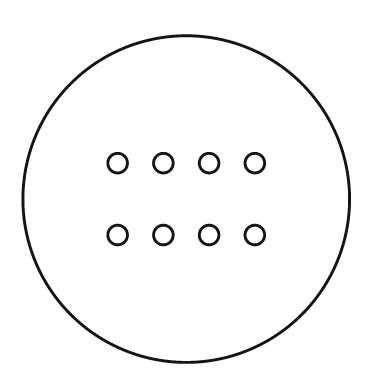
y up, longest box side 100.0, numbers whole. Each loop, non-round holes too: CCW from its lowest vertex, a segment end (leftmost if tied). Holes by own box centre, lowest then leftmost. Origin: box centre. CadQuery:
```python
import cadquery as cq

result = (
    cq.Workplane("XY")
    .moveTo(0.0, 0.0)
    .circle(50.0)
    .moveTo(-21.0, -11.0)
    .circle(3.0)
    .moveTo(-7.0, -11.0)
    .circle(3.0)
    .moveTo(7.0, -11.0)
    .circle(3.0)
    .moveTo(21.0, -11.0)
    .circle(3.0)
    .moveTo(-21.0, 11.0)
    .circle(3.0)
    .moveTo(-7.0, 11.0)
    .circle(3.0)
    .moveTo(7.0, 11.0)
    .circle(3.0)
    .moveTo(21.0, 11.0)
    .circle(3.0)
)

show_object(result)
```